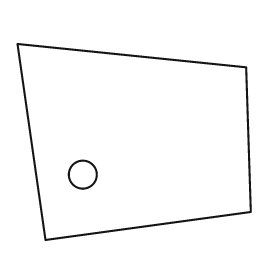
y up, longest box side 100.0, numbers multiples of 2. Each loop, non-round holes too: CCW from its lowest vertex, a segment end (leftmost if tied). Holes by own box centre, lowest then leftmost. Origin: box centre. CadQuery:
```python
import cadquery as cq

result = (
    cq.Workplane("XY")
    .moveTo(-38.0, -42.0)
    .lineTo(50.0, -30.0)
    .lineTo(48.0, 32.0)
    .lineTo(-50.0, 42.0)
    .close()
    .moveTo(-22.0, -14.0)
    .circle(6.0)
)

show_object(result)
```